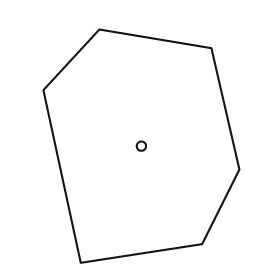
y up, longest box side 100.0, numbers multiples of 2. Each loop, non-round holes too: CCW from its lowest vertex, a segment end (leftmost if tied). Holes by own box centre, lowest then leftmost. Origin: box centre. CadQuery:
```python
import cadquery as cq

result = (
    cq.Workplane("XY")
    .moveTo(-26.0, -50.0)
    .lineTo(26.0, -42.0)
    .lineTo(42.0, -10.0)
    .lineTo(30.0, 42.0)
    .lineTo(-18.0, 50.0)
    .lineTo(-42.0, 24.0)
    .close()
    .moveTo(0.0, 0.0)
    .circle(2.0)
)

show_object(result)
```